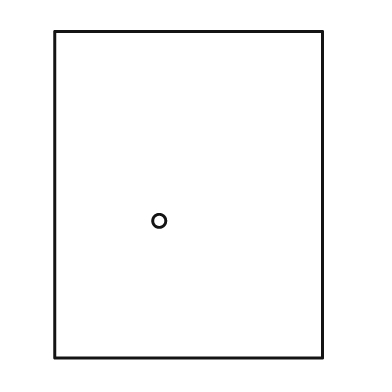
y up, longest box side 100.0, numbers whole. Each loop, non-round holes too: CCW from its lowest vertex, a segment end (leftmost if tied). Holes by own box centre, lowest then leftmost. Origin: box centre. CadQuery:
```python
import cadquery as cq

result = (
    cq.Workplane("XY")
    .moveTo(-41.0, -50.0)
    .lineTo(41.0, -50.0)
    .lineTo(41.0, 50.0)
    .lineTo(-41.0, 50.0)
    .close()
    .moveTo(-9.0, -8.0)
    .circle(2.0)
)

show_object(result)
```